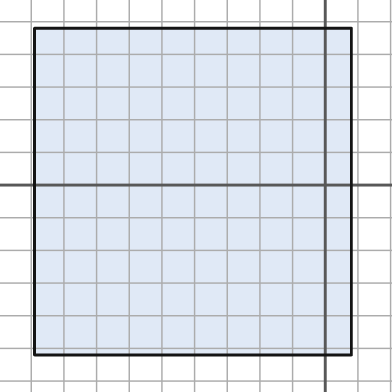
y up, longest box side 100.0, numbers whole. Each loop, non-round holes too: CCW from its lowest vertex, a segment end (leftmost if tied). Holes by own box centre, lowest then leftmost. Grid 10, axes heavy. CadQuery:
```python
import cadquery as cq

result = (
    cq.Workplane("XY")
    .moveTo(-89.0, -52.0)
    .lineTo(8.0, -52.0)
    .lineTo(8.0, 48.0)
    .lineTo(-89.0, 48.0)
    .close()
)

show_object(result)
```